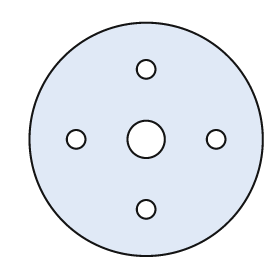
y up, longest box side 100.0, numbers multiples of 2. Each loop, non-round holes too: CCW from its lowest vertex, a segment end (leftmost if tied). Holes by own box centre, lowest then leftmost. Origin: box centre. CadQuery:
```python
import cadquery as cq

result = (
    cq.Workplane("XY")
    .moveTo(0.0, 0.0)
    .circle(50.0)
    .moveTo(0.0, -30.0)
    .circle(4.0)
    .moveTo(-30.0, 0.0)
    .circle(4.0)
    .moveTo(0.0, 0.0)
    .circle(8.0)
    .moveTo(30.0, 0.0)
    .circle(4.0)
    .moveTo(0.0, 30.0)
    .circle(4.0)
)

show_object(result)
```